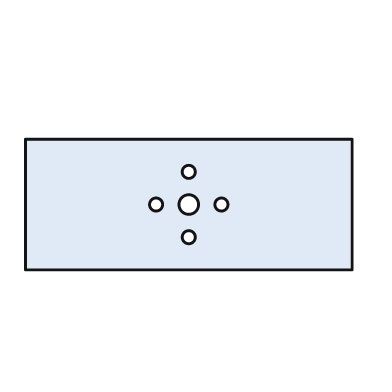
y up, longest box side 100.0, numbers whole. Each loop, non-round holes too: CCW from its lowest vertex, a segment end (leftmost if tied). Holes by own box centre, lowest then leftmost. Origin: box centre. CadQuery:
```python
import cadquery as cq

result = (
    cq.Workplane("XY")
    .moveTo(-50.0, -20.0)
    .lineTo(50.0, -20.0)
    .lineTo(50.0, 20.0)
    .lineTo(-50.0, 20.0)
    .close()
    .moveTo(0.0, -10.0)
    .circle(2.0)
    .moveTo(-10.0, 0.0)
    .circle(2.0)
    .moveTo(0.0, 0.0)
    .circle(3.0)
    .moveTo(10.0, 0.0)
    .circle(2.0)
    .moveTo(0.0, 10.0)
    .circle(2.0)
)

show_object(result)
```